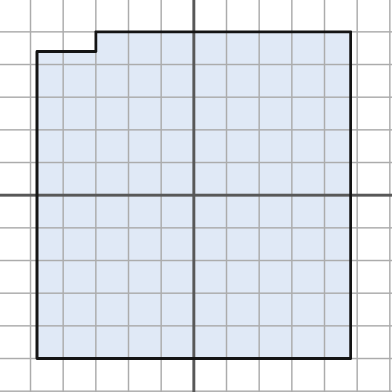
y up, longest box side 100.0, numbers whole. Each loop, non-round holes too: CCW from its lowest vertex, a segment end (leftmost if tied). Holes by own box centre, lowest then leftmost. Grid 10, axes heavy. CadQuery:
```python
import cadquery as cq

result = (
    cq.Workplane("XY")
    .moveTo(-48.0, -50.0)
    .lineTo(48.0, -50.0)
    .lineTo(48.0, 50.0)
    .lineTo(-30.0, 50.0)
    .lineTo(-30.0, 44.0)
    .lineTo(-48.0, 44.0)
    .close()
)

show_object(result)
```